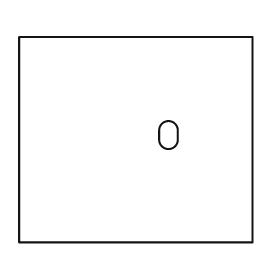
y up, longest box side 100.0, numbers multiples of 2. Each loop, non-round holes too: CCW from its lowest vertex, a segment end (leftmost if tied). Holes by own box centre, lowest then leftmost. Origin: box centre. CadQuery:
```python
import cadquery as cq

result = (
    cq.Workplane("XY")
    .moveTo(-50.0, -44.0)
    .lineTo(50.0, -44.0)
    .lineTo(50.0, 44.0)
    .lineTo(-50.0, 44.0)
    .close()
    .moveTo(10.0, 0.0)
    .threePointArc((14.0, -4.0), (18.0, 0.0))
    .lineTo(18.0, 4.0)
    .threePointArc((14.0, 8.0), (10.0, 4.0))
    .close()
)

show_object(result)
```